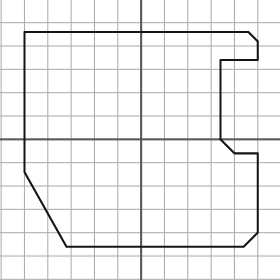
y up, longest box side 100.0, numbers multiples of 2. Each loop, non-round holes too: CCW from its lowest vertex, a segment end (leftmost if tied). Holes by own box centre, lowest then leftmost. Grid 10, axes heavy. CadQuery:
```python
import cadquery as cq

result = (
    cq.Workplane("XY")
    .moveTo(-32.0, -46.0)
    .lineTo(44.0, -46.0)
    .lineTo(50.0, -40.0)
    .lineTo(50.0, -6.0)
    .lineTo(40.0, -6.0)
    .lineTo(34.0, 0.0)
    .lineTo(34.0, 34.0)
    .lineTo(50.0, 34.0)
    .lineTo(50.0, 42.0)
    .lineTo(46.0, 46.0)
    .lineTo(-50.0, 46.0)
    .lineTo(-50.0, -14.0)
    .close()
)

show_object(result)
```